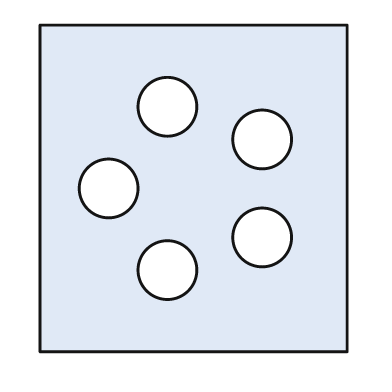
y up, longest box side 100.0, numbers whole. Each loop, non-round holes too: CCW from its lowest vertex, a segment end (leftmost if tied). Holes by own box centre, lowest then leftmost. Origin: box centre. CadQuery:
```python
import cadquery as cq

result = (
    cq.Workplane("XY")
    .moveTo(-47.0, -50.0)
    .lineTo(47.0, -50.0)
    .lineTo(47.0, 50.0)
    .lineTo(-47.0, 50.0)
    .close()
    .moveTo(-8.0, -25.0)
    .circle(9.0)
    .moveTo(21.0, -15.0)
    .circle(9.0)
    .moveTo(-26.0, 0.0)
    .circle(9.0)
    .moveTo(21.0, 15.0)
    .circle(9.0)
    .moveTo(-8.0, 25.0)
    .circle(9.0)
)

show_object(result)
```